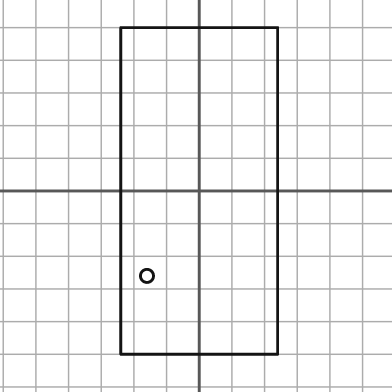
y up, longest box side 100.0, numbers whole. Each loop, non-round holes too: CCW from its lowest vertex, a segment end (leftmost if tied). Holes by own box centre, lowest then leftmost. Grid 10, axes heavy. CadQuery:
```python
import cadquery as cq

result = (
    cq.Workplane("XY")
    .moveTo(-24.0, -50.0)
    .lineTo(24.0, -50.0)
    .lineTo(24.0, 50.0)
    .lineTo(-24.0, 50.0)
    .close()
    .moveTo(-16.0, -26.0)
    .circle(2.0)
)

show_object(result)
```